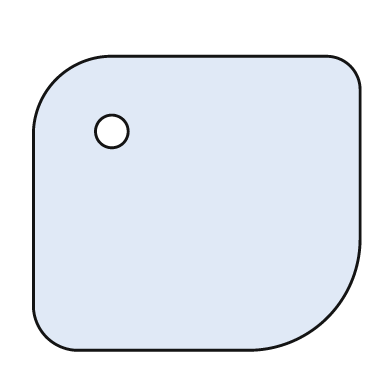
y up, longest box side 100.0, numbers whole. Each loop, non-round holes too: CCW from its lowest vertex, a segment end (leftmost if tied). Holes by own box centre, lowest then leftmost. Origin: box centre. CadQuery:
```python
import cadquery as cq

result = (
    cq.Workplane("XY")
    .moveTo(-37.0, -45.0)
    .lineTo(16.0, -45.0)
    .threePointArc((40.0, -35.0), (50.0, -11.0))
    .lineTo(50.0, 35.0)
    .threePointArc((47.0, 42.0), (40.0, 45.0))
    .lineTo(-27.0, 45.0)
    .threePointArc((-43.0, 38.0), (-50.0, 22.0))
    .lineTo(-50.0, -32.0)
    .threePointArc((-46.0, -41.0), (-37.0, -45.0))
    .close()
    .moveTo(-26.0, 22.0)
    .circle(5.0)
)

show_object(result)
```